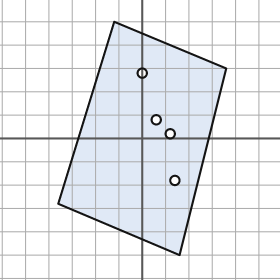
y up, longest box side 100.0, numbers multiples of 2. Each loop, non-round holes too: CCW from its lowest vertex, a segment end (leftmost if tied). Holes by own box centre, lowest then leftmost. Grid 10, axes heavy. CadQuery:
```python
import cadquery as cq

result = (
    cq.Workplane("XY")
    .moveTo(16.0, -50.0)
    .lineTo(36.0, 30.0)
    .lineTo(-12.0, 50.0)
    .lineTo(-36.0, -28.0)
    .close()
    .moveTo(14.0, -18.0)
    .circle(2.0)
    .moveTo(12.0, 2.0)
    .circle(2.0)
    .moveTo(6.0, 8.0)
    .circle(2.0)
    .moveTo(0.0, 28.0)
    .circle(2.0)
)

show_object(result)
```